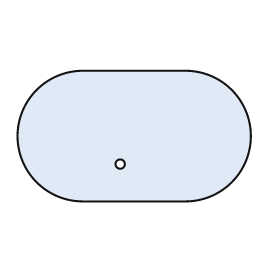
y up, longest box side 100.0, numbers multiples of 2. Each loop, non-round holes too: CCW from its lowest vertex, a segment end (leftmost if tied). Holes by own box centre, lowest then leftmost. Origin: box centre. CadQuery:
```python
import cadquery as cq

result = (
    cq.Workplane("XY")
    .moveTo(-22.0, -28.0)
    .lineTo(22.0, -28.0)
    .threePointArc((50.0, 0.0), (22.0, 28.0))
    .lineTo(-22.0, 28.0)
    .threePointArc((-50.0, 0.0), (-22.0, -28.0))
    .close()
    .moveTo(-6.0, -12.0)
    .circle(2.0)
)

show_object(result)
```